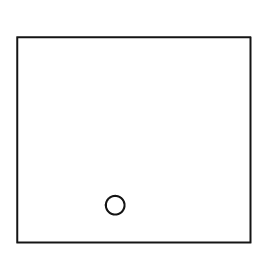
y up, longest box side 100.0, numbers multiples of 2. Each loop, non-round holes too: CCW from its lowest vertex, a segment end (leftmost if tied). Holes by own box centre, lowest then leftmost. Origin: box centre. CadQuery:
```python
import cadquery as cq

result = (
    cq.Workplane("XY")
    .moveTo(-50.0, -44.0)
    .lineTo(50.0, -44.0)
    .lineTo(50.0, 44.0)
    .lineTo(-50.0, 44.0)
    .close()
    .moveTo(-8.0, -28.0)
    .circle(4.0)
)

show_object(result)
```